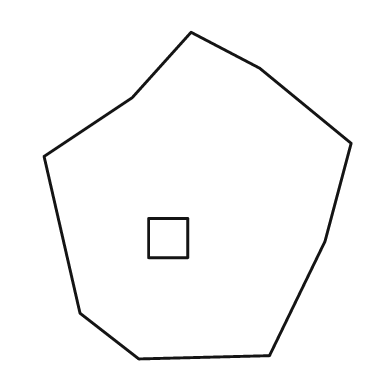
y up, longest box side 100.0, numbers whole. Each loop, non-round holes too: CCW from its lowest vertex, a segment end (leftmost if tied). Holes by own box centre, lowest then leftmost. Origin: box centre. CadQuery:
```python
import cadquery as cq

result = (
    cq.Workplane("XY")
    .moveTo(-18.0, -50.0)
    .lineTo(22.0, -49.0)
    .lineTo(39.0, -14.0)
    .lineTo(47.0, 16.0)
    .lineTo(19.0, 39.0)
    .lineTo(-2.0, 50.0)
    .lineTo(-20.0, 30.0)
    .lineTo(-47.0, 12.0)
    .lineTo(-36.0, -36.0)
    .close()
    .moveTo(-15.0, -19.0)
    .lineTo(-3.0, -19.0)
    .lineTo(-3.0, -7.0)
    .lineTo(-15.0, -7.0)
    .close()
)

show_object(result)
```